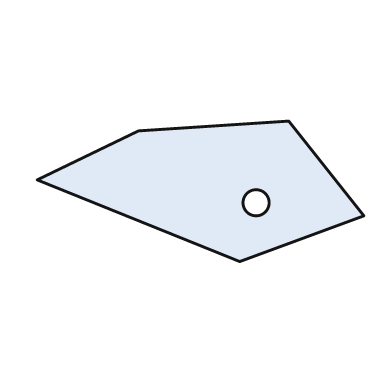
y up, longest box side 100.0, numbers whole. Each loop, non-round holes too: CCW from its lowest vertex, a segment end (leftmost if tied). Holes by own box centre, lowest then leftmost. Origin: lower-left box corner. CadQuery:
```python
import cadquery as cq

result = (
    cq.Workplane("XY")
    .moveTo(62.0, 0.0)
    .lineTo(100.0, 14.0)
    .lineTo(77.0, 43.0)
    .lineTo(31.0, 40.0)
    .lineTo(0.0, 25.0)
    .close()
    .moveTo(67.0, 18.0)
    .circle(4.0)
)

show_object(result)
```